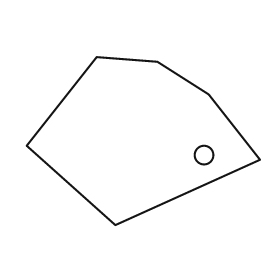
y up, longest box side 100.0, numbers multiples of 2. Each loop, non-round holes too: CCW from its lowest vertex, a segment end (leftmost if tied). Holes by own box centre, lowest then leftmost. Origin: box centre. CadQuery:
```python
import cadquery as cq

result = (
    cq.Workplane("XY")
    .moveTo(-12.0, -36.0)
    .lineTo(50.0, -8.0)
    .lineTo(28.0, 20.0)
    .lineTo(6.0, 34.0)
    .lineTo(-20.0, 36.0)
    .lineTo(-50.0, -2.0)
    .close()
    .moveTo(26.0, -6.0)
    .circle(4.0)
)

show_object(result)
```